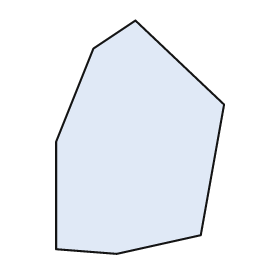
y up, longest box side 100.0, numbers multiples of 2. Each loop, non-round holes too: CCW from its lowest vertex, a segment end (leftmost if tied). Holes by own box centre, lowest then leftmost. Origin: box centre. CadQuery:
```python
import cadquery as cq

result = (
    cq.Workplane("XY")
    .moveTo(-10.0, -50.0)
    .lineTo(26.0, -42.0)
    .lineTo(36.0, 14.0)
    .lineTo(-2.0, 50.0)
    .lineTo(-20.0, 38.0)
    .lineTo(-36.0, -2.0)
    .lineTo(-36.0, -48.0)
    .close()
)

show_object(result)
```